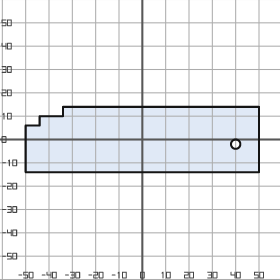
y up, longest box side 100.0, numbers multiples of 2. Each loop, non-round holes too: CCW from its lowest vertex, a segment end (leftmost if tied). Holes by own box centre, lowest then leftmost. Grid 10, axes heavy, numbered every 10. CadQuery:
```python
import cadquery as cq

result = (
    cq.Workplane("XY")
    .moveTo(-50.0, -14.0)
    .lineTo(50.0, -14.0)
    .lineTo(50.0, 14.0)
    .lineTo(-34.0, 14.0)
    .lineTo(-34.0, 10.0)
    .lineTo(-44.0, 10.0)
    .lineTo(-44.0, 6.0)
    .lineTo(-50.0, 6.0)
    .close()
    .moveTo(40.0, -2.0)
    .circle(2.0)
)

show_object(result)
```